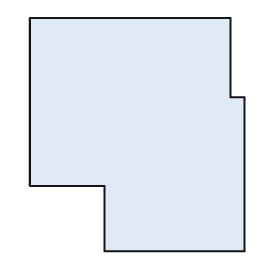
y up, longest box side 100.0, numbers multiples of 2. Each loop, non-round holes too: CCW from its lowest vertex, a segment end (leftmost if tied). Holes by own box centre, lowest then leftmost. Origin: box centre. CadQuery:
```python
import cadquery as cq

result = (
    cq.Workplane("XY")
    .moveTo(-14.0, -50.0)
    .lineTo(46.0, -50.0)
    .lineTo(46.0, 16.0)
    .lineTo(40.0, 16.0)
    .lineTo(40.0, 50.0)
    .lineTo(-46.0, 50.0)
    .lineTo(-46.0, -22.0)
    .lineTo(-14.0, -22.0)
    .close()
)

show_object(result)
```